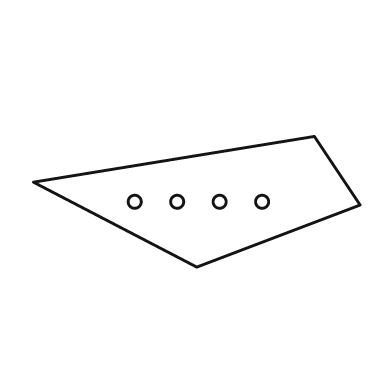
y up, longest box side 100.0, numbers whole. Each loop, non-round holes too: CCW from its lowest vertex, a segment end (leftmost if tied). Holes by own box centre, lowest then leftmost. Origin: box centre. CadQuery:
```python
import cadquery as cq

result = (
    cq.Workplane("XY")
    .moveTo(0.0, -20.0)
    .lineTo(50.0, -1.0)
    .lineTo(36.0, 20.0)
    .lineTo(-50.0, 6.0)
    .close()
    .moveTo(-19.0, 0.0)
    .circle(2.0)
    .moveTo(-6.0, 0.0)
    .circle(2.0)
    .moveTo(7.0, 0.0)
    .circle(2.0)
    .moveTo(20.0, 0.0)
    .circle(2.0)
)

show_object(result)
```